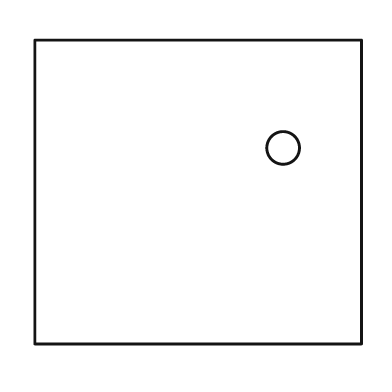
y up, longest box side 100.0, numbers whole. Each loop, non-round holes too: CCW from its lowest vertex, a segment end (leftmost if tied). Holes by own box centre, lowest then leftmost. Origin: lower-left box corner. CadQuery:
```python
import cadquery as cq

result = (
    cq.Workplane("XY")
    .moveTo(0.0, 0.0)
    .lineTo(100.0, 0.0)
    .lineTo(100.0, 93.0)
    .lineTo(0.0, 93.0)
    .close()
    .moveTo(76.0, 60.0)
    .circle(5.0)
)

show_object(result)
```